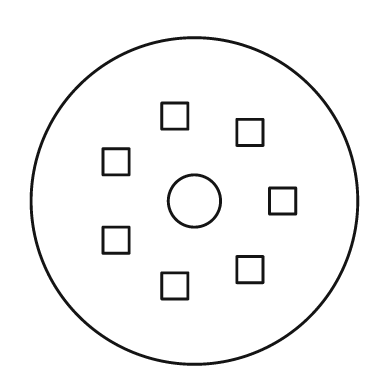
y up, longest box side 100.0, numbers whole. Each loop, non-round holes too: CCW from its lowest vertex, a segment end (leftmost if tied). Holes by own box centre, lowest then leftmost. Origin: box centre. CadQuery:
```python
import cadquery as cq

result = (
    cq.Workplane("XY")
    .moveTo(0.0, 0.0)
    .circle(50.0)
    .moveTo(-10.0, -30.0)
    .lineTo(-2.0, -30.0)
    .lineTo(-2.0, -22.0)
    .lineTo(-10.0, -22.0)
    .close()
    .moveTo(13.0, -25.0)
    .lineTo(21.0, -25.0)
    .lineTo(21.0, -17.0)
    .lineTo(13.0, -17.0)
    .close()
    .moveTo(-28.0, -16.0)
    .lineTo(-20.0, -16.0)
    .lineTo(-20.0, -8.0)
    .lineTo(-28.0, -8.0)
    .close()
    .moveTo(0.0, 0.0)
    .circle(8.0)
    .moveTo(23.0, -4.0)
    .lineTo(31.0, -4.0)
    .lineTo(31.0, 4.0)
    .lineTo(23.0, 4.0)
    .close()
    .moveTo(-28.0, 8.0)
    .lineTo(-20.0, 8.0)
    .lineTo(-20.0, 16.0)
    .lineTo(-28.0, 16.0)
    .close()
    .moveTo(13.0, 17.0)
    .lineTo(21.0, 17.0)
    .lineTo(21.0, 25.0)
    .lineTo(13.0, 25.0)
    .close()
    .moveTo(-10.0, 22.0)
    .lineTo(-2.0, 22.0)
    .lineTo(-2.0, 30.0)
    .lineTo(-10.0, 30.0)
    .close()
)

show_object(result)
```